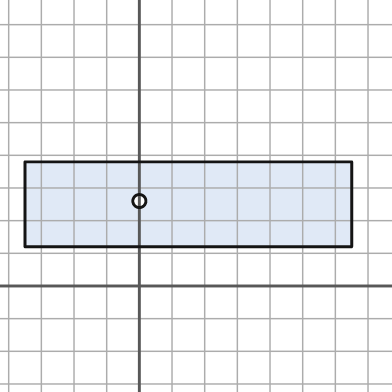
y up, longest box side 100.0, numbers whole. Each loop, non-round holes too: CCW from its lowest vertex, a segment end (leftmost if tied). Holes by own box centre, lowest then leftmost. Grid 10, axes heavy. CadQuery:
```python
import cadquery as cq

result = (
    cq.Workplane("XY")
    .moveTo(-35.0, 12.0)
    .lineTo(65.0, 12.0)
    .lineTo(65.0, 38.0)
    .lineTo(-35.0, 38.0)
    .close()
    .moveTo(0.0, 26.0)
    .circle(2.0)
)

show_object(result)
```